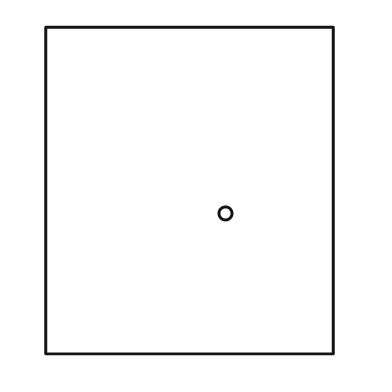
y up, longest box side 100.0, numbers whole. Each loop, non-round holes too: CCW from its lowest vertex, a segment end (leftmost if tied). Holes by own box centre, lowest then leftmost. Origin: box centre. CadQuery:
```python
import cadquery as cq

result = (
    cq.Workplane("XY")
    .moveTo(-44.0, -50.0)
    .lineTo(44.0, -50.0)
    .lineTo(44.0, 50.0)
    .lineTo(-44.0, 50.0)
    .close()
    .moveTo(11.0, -7.0)
    .circle(2.0)
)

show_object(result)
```